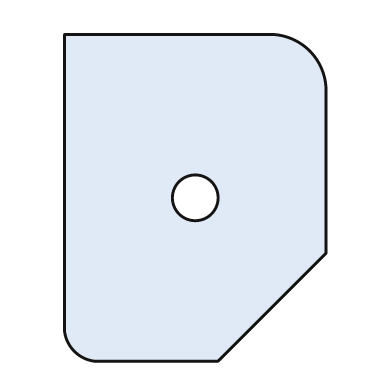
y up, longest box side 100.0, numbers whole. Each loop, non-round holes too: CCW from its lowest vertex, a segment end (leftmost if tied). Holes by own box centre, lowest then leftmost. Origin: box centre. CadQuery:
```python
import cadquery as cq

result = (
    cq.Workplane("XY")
    .moveTo(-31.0, -50.0)
    .lineTo(7.0, -50.0)
    .lineTo(40.0, -17.0)
    .lineTo(40.0, 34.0)
    .threePointArc((35.0, 45.0), (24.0, 50.0))
    .lineTo(-40.0, 50.0)
    .lineTo(-40.0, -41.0)
    .threePointArc((-37.0, -47.0), (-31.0, -50.0))
    .close()
    .moveTo(0.0, 0.0)
    .circle(7.0)
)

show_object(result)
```